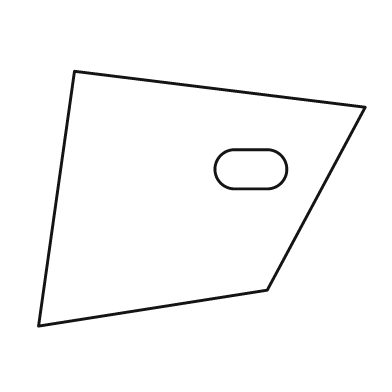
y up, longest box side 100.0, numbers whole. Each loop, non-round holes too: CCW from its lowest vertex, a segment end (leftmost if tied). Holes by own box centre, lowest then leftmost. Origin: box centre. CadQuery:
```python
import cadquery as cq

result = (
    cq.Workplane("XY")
    .moveTo(-50.0, -39.0)
    .lineTo(20.0, -28.0)
    .lineTo(50.0, 28.0)
    .lineTo(-39.0, 39.0)
    .close()
    .moveTo(10.0, 3.0)
    .lineTo(20.0, 3.0)
    .threePointArc((26.0, 9.0), (20.0, 15.0))
    .lineTo(10.0, 15.0)
    .threePointArc((4.0, 9.0), (10.0, 3.0))
    .close()
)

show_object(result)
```